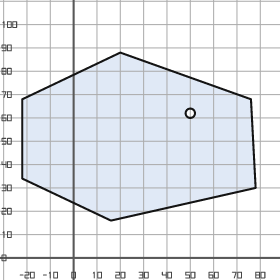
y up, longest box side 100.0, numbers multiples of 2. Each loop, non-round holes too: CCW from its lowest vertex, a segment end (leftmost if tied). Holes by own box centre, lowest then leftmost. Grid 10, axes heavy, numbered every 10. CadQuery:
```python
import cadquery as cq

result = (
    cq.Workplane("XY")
    .moveTo(16.0, 16.0)
    .lineTo(78.0, 30.0)
    .lineTo(76.0, 68.0)
    .lineTo(20.0, 88.0)
    .lineTo(-22.0, 68.0)
    .lineTo(-22.0, 34.0)
    .close()
    .moveTo(50.0, 62.0)
    .circle(2.0)
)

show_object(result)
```